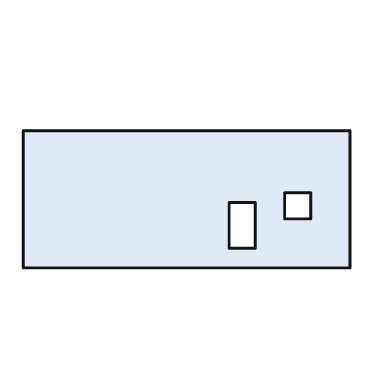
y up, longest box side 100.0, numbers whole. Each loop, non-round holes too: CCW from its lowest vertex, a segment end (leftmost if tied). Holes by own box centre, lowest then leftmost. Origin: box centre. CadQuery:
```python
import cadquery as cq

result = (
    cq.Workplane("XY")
    .moveTo(-50.0, -21.0)
    .lineTo(50.0, -21.0)
    .lineTo(50.0, 21.0)
    .lineTo(-50.0, 21.0)
    .close()
    .moveTo(13.0, -15.0)
    .lineTo(21.0, -15.0)
    .lineTo(21.0, -1.0)
    .lineTo(13.0, -1.0)
    .close()
    .moveTo(30.0, -6.0)
    .lineTo(38.0, -6.0)
    .lineTo(38.0, 2.0)
    .lineTo(30.0, 2.0)
    .close()
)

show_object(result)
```